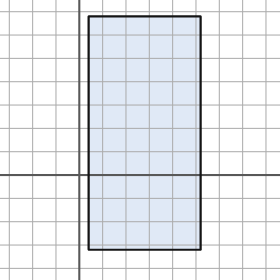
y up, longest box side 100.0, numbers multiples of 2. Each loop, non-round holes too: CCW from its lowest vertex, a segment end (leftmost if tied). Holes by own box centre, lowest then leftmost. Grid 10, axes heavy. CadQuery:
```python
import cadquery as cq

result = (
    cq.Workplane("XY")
    .moveTo(4.0, -32.0)
    .lineTo(52.0, -32.0)
    .lineTo(52.0, 68.0)
    .lineTo(4.0, 68.0)
    .close()
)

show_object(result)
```